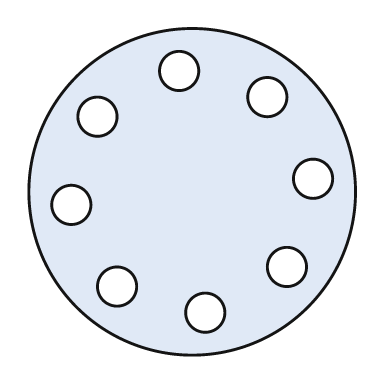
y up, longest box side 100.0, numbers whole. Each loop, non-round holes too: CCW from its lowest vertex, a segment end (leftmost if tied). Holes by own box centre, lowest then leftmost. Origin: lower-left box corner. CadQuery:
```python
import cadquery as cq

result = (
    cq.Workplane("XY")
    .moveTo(50.0, 50.0)
    .circle(50.0)
    .moveTo(54.0, 13.0)
    .circle(6.0)
    .moveTo(27.0, 21.0)
    .circle(6.0)
    .moveTo(79.0, 27.0)
    .circle(6.0)
    .moveTo(13.0, 46.0)
    .circle(6.0)
    .moveTo(87.0, 54.0)
    .circle(6.0)
    .moveTo(21.0, 73.0)
    .circle(6.0)
    .moveTo(73.0, 79.0)
    .circle(6.0)
    .moveTo(46.0, 87.0)
    .circle(6.0)
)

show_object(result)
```